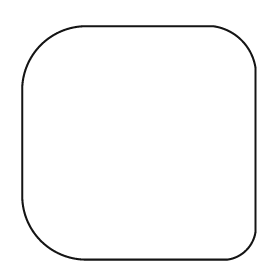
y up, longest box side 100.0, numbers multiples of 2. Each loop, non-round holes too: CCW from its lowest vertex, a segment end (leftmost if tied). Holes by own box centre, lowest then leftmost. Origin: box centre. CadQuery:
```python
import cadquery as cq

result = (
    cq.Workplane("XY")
    .moveTo(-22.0, -50.0)
    .lineTo(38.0, -50.0)
    .threePointArc((46.0, -46.0), (50.0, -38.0))
    .lineTo(50.0, 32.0)
    .threePointArc((44.0, 44.0), (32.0, 50.0))
    .lineTo(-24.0, 50.0)
    .threePointArc((-42.0, 42.0), (-50.0, 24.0))
    .lineTo(-50.0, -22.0)
    .threePointArc((-42.0, -42.0), (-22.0, -50.0))
    .close()
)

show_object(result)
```